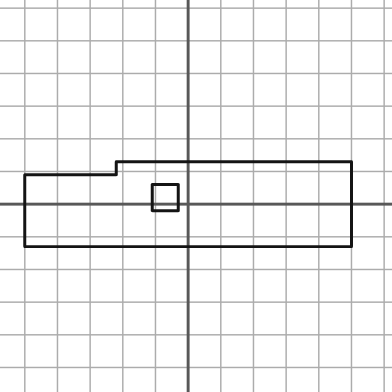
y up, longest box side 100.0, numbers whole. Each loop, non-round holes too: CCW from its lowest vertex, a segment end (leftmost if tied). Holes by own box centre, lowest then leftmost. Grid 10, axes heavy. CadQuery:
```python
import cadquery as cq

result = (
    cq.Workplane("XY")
    .moveTo(-50.0, -13.0)
    .lineTo(50.0, -13.0)
    .lineTo(50.0, 13.0)
    .lineTo(-22.0, 13.0)
    .lineTo(-22.0, 9.0)
    .lineTo(-50.0, 9.0)
    .close()
    .moveTo(-11.0, -2.0)
    .lineTo(-3.0, -2.0)
    .lineTo(-3.0, 6.0)
    .lineTo(-11.0, 6.0)
    .close()
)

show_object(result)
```